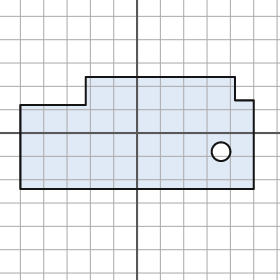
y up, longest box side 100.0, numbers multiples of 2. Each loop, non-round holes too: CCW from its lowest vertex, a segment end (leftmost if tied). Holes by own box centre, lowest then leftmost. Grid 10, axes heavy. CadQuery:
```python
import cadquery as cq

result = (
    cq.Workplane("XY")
    .moveTo(-50.0, -24.0)
    .lineTo(50.0, -24.0)
    .lineTo(50.0, 14.0)
    .lineTo(42.0, 14.0)
    .lineTo(42.0, 24.0)
    .lineTo(-22.0, 24.0)
    .lineTo(-22.0, 12.0)
    .lineTo(-50.0, 12.0)
    .close()
    .moveTo(36.0, -8.0)
    .circle(4.0)
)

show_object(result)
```